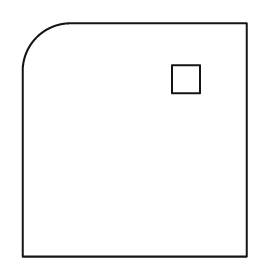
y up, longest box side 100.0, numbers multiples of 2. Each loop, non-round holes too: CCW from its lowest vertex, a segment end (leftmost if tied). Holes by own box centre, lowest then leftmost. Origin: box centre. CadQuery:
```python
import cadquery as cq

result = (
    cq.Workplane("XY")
    .moveTo(-48.0, -50.0)
    .lineTo(48.0, -50.0)
    .lineTo(48.0, 50.0)
    .lineTo(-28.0, 50.0)
    .threePointArc((-42.0, 44.0), (-48.0, 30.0))
    .close()
    .moveTo(16.0, 20.0)
    .lineTo(28.0, 20.0)
    .lineTo(28.0, 32.0)
    .lineTo(16.0, 32.0)
    .close()
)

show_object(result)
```